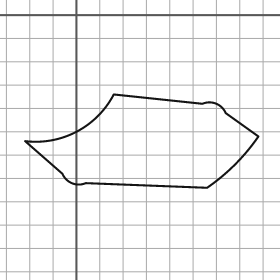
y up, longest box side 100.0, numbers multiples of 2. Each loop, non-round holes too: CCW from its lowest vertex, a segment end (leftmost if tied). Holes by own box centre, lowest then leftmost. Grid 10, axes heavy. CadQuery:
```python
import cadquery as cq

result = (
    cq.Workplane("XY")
    .moveTo(56.0, -74.0)
    .threePointArc((68.0, -64.0), (78.0, -52.0))
    .lineTo(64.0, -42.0)
    .threePointArc((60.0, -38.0), (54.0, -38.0))
    .lineTo(16.0, -34.0)
    .threePointArc((0.0, -50.0), (-22.0, -54.0))
    .lineTo(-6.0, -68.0)
    .threePointArc((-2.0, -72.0), (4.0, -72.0))
    .close()
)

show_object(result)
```